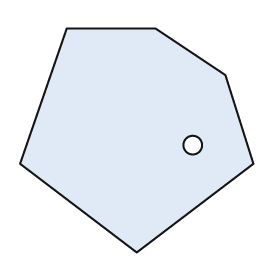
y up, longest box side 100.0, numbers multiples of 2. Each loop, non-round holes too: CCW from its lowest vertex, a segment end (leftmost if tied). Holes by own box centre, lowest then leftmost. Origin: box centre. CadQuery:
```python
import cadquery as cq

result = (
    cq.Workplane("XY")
    .moveTo(0.0, -48.0)
    .lineTo(50.0, -10.0)
    .lineTo(38.0, 28.0)
    .lineTo(8.0, 48.0)
    .lineTo(-30.0, 48.0)
    .lineTo(-50.0, -10.0)
    .close()
    .moveTo(24.0, -2.0)
    .circle(4.0)
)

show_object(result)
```